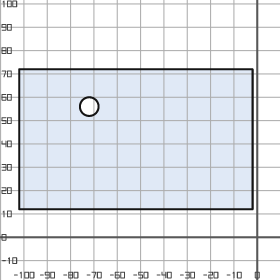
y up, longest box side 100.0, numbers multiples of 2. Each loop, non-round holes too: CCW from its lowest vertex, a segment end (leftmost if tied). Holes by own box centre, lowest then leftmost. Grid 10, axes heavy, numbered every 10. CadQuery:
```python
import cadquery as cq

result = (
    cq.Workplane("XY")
    .moveTo(-102.0, 12.0)
    .lineTo(-2.0, 12.0)
    .lineTo(-2.0, 72.0)
    .lineTo(-102.0, 72.0)
    .close()
    .moveTo(-72.0, 56.0)
    .circle(4.0)
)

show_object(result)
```